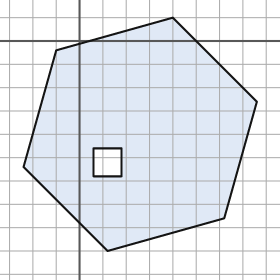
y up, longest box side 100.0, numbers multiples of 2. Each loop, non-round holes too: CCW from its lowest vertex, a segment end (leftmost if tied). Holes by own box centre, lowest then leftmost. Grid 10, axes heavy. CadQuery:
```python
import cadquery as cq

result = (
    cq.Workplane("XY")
    .moveTo(12.0, -90.0)
    .lineTo(62.0, -76.0)
    .lineTo(76.0, -26.0)
    .lineTo(40.0, 10.0)
    .lineTo(-10.0, -4.0)
    .lineTo(-24.0, -54.0)
    .close()
    .moveTo(6.0, -58.0)
    .lineTo(18.0, -58.0)
    .lineTo(18.0, -46.0)
    .lineTo(6.0, -46.0)
    .close()
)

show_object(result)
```